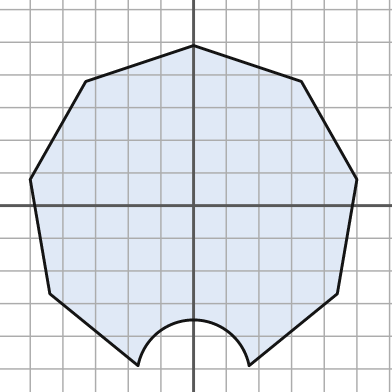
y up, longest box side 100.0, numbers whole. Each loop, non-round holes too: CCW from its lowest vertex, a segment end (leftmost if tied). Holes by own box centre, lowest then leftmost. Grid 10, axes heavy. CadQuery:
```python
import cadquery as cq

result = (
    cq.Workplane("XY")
    .moveTo(-17.0, -49.0)
    .threePointArc((0.0, -35.0), (17.0, -49.0))
    .lineTo(44.0, -27.0)
    .lineTo(50.0, 8.0)
    .lineTo(33.0, 38.0)
    .lineTo(0.0, 49.0)
    .lineTo(-33.0, 38.0)
    .lineTo(-50.0, 8.0)
    .lineTo(-44.0, -27.0)
    .close()
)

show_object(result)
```